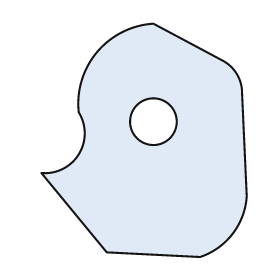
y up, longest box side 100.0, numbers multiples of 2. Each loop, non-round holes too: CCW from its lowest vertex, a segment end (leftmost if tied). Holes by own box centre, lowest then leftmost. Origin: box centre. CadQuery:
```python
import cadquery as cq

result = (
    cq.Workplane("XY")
    .moveTo(24.0, -50.0)
    .threePointArc((38.0, -40.0), (44.0, -24.0))
    .lineTo(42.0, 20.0)
    .threePointArc((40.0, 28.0), (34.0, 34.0))
    .lineTo(4.0, 50.0)
    .threePointArc((-20.0, 38.0), (-28.0, 12.0))
    .threePointArc((-28.0, -6.0), (-44.0, -14.0))
    .lineTo(-16.0, -48.0)
    .close()
    .moveTo(4.0, 8.0)
    .circle(10.0)
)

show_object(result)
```